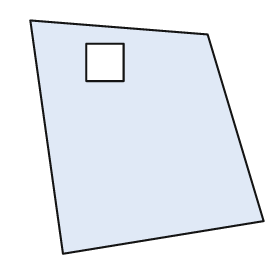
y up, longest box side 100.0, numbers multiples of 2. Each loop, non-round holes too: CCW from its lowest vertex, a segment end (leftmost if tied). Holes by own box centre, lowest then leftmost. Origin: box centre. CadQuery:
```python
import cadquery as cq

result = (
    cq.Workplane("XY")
    .moveTo(-36.0, -50.0)
    .lineTo(50.0, -36.0)
    .lineTo(26.0, 44.0)
    .lineTo(-50.0, 50.0)
    .close()
    .moveTo(-26.0, 24.0)
    .lineTo(-10.0, 24.0)
    .lineTo(-10.0, 40.0)
    .lineTo(-26.0, 40.0)
    .close()
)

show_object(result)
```